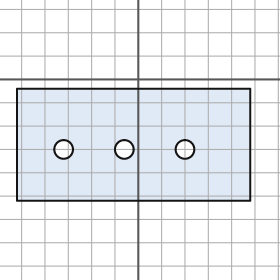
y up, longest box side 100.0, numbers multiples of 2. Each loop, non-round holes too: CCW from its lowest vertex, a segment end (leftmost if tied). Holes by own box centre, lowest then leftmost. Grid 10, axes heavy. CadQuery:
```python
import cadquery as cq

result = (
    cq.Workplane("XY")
    .moveTo(-52.0, -52.0)
    .lineTo(48.0, -52.0)
    .lineTo(48.0, -4.0)
    .lineTo(-52.0, -4.0)
    .close()
    .moveTo(-32.0, -30.0)
    .circle(4.0)
    .moveTo(-6.0, -30.0)
    .circle(4.0)
    .moveTo(20.0, -30.0)
    .circle(4.0)
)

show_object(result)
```